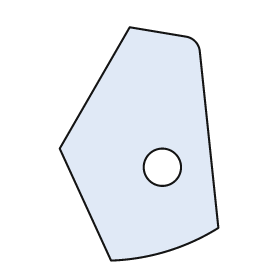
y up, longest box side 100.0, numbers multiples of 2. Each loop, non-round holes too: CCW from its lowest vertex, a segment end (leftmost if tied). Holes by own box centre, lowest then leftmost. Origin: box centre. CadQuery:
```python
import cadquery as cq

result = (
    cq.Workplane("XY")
    .moveTo(-12.0, -50.0)
    .threePointArc((12.0, -46.0), (34.0, -36.0))
    .lineTo(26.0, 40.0)
    .threePointArc((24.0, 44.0), (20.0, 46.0))
    .lineTo(-4.0, 50.0)
    .lineTo(-34.0, -2.0)
    .close()
    .moveTo(10.0, -10.0)
    .circle(8.0)
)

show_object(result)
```